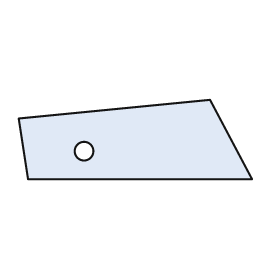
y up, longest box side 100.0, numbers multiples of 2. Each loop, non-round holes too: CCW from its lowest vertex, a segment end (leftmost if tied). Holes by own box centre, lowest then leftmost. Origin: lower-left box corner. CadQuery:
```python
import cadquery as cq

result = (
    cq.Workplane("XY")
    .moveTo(4.0, 0.0)
    .lineTo(100.0, 0.0)
    .lineTo(82.0, 34.0)
    .lineTo(0.0, 26.0)
    .close()
    .moveTo(28.0, 12.0)
    .circle(4.0)
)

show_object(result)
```